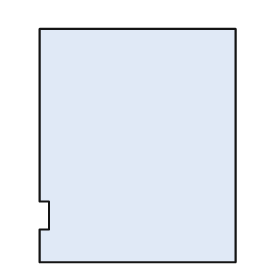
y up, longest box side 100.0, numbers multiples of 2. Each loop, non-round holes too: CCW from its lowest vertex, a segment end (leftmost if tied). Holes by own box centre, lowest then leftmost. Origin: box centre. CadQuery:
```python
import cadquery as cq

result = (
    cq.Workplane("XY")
    .moveTo(-42.0, -50.0)
    .lineTo(42.0, -50.0)
    .lineTo(42.0, 50.0)
    .lineTo(-42.0, 50.0)
    .lineTo(-42.0, -24.0)
    .lineTo(-38.0, -24.0)
    .lineTo(-38.0, -36.0)
    .lineTo(-42.0, -36.0)
    .close()
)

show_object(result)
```